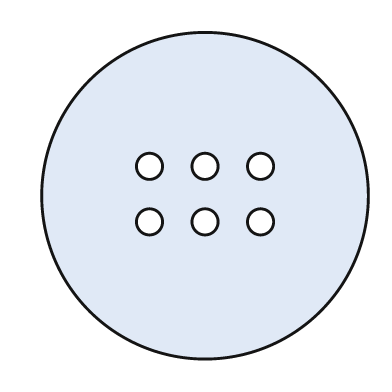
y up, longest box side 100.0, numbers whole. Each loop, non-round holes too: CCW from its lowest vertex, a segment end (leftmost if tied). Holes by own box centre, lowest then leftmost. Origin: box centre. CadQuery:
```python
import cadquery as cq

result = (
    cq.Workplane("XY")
    .moveTo(0.0, 0.0)
    .circle(50.0)
    .moveTo(-17.0, -8.0)
    .circle(4.0)
    .moveTo(0.0, -8.0)
    .circle(4.0)
    .moveTo(17.0, -8.0)
    .circle(4.0)
    .moveTo(-17.0, 9.0)
    .circle(4.0)
    .moveTo(0.0, 9.0)
    .circle(4.0)
    .moveTo(17.0, 9.0)
    .circle(4.0)
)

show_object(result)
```